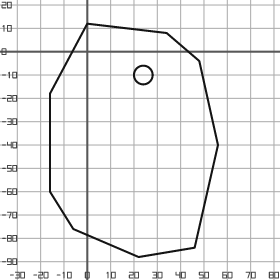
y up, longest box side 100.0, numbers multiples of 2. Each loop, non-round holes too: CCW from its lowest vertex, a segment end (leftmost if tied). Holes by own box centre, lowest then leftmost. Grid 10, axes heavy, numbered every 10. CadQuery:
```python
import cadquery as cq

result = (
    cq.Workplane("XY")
    .moveTo(22.0, -88.0)
    .lineTo(46.0, -84.0)
    .lineTo(56.0, -40.0)
    .lineTo(48.0, -4.0)
    .lineTo(34.0, 8.0)
    .lineTo(0.0, 12.0)
    .lineTo(-16.0, -18.0)
    .lineTo(-16.0, -60.0)
    .lineTo(-6.0, -76.0)
    .close()
    .moveTo(24.0, -10.0)
    .circle(4.0)
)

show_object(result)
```